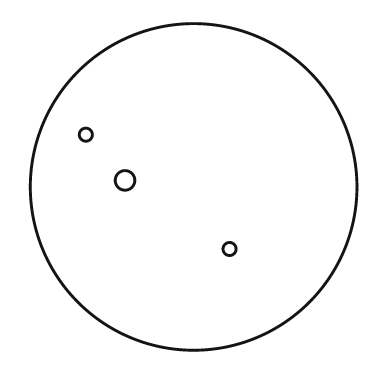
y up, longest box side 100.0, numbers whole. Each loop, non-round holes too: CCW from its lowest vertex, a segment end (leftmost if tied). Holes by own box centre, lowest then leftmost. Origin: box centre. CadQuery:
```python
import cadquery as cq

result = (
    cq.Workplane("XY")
    .moveTo(0.0, 0.0)
    .circle(50.0)
    .moveTo(11.0, -19.0)
    .circle(2.0)
    .moveTo(-21.0, 2.0)
    .circle(3.0)
    .moveTo(-33.0, 16.0)
    .circle(2.0)
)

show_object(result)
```